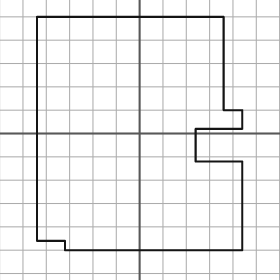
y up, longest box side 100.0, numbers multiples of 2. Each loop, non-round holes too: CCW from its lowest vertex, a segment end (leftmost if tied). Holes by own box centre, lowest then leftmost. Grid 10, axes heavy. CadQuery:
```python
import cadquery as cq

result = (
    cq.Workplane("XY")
    .moveTo(-32.0, -50.0)
    .lineTo(44.0, -50.0)
    .lineTo(44.0, -12.0)
    .lineTo(24.0, -12.0)
    .lineTo(24.0, 2.0)
    .lineTo(44.0, 2.0)
    .lineTo(44.0, 10.0)
    .lineTo(36.0, 10.0)
    .lineTo(36.0, 50.0)
    .lineTo(-44.0, 50.0)
    .lineTo(-44.0, -46.0)
    .lineTo(-32.0, -46.0)
    .close()
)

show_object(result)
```